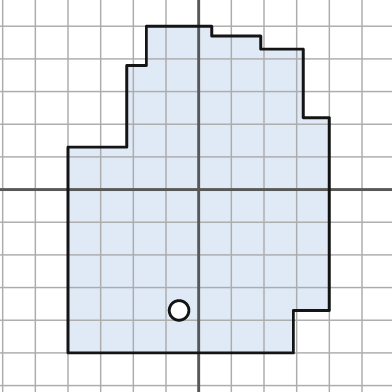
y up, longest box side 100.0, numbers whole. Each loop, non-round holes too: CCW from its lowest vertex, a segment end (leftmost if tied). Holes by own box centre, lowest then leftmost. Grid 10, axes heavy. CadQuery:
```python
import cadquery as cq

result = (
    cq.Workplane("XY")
    .moveTo(-40.0, -50.0)
    .lineTo(29.0, -50.0)
    .lineTo(29.0, -37.0)
    .lineTo(40.0, -37.0)
    .lineTo(40.0, 22.0)
    .lineTo(32.0, 22.0)
    .lineTo(32.0, 43.0)
    .lineTo(19.0, 43.0)
    .lineTo(19.0, 47.0)
    .lineTo(4.0, 47.0)
    .lineTo(4.0, 50.0)
    .lineTo(-16.0, 50.0)
    .lineTo(-16.0, 38.0)
    .lineTo(-22.0, 38.0)
    .lineTo(-22.0, 13.0)
    .lineTo(-40.0, 13.0)
    .close()
    .moveTo(-6.0, -37.0)
    .circle(3.0)
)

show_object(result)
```